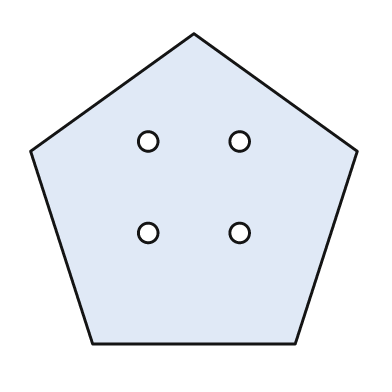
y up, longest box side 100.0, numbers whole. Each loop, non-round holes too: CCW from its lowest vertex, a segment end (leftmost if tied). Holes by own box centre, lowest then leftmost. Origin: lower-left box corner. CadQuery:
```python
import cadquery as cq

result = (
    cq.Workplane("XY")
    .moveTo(19.0, 0.0)
    .lineTo(81.0, 0.0)
    .lineTo(100.0, 59.0)
    .lineTo(50.0, 95.0)
    .lineTo(0.0, 59.0)
    .close()
    .moveTo(36.0, 34.0)
    .circle(3.0)
    .moveTo(64.0, 34.0)
    .circle(3.0)
    .moveTo(36.0, 62.0)
    .circle(3.0)
    .moveTo(64.0, 62.0)
    .circle(3.0)
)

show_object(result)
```